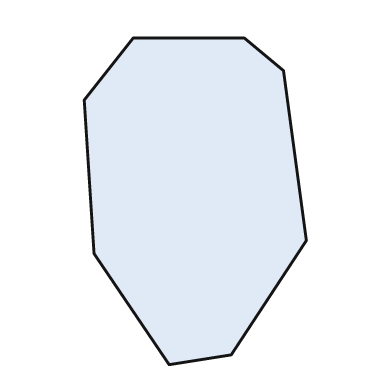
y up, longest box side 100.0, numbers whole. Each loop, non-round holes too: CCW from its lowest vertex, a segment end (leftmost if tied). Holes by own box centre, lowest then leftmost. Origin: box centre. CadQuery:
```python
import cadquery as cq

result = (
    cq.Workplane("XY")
    .moveTo(-8.0, -50.0)
    .lineTo(11.0, -47.0)
    .lineTo(34.0, -12.0)
    .lineTo(27.0, 40.0)
    .lineTo(15.0, 50.0)
    .lineTo(-19.0, 50.0)
    .lineTo(-34.0, 31.0)
    .lineTo(-31.0, -16.0)
    .close()
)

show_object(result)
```